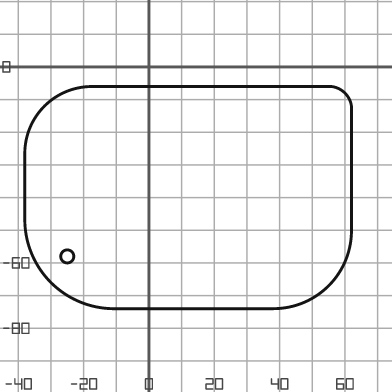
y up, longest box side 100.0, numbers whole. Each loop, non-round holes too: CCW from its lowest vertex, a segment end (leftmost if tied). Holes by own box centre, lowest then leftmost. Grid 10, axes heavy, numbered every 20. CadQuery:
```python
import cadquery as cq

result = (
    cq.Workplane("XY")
    .moveTo(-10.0, -74.0)
    .lineTo(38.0, -74.0)
    .threePointArc((55.0, -67.0), (62.0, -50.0))
    .lineTo(62.0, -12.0)
    .threePointArc((60.0, -8.0), (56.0, -6.0))
    .lineTo(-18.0, -6.0)
    .threePointArc((-32.0, -12.0), (-38.0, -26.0))
    .lineTo(-38.0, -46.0)
    .threePointArc((-30.0, -66.0), (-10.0, -74.0))
    .close()
    .moveTo(-25.0, -58.0)
    .circle(2.0)
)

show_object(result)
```